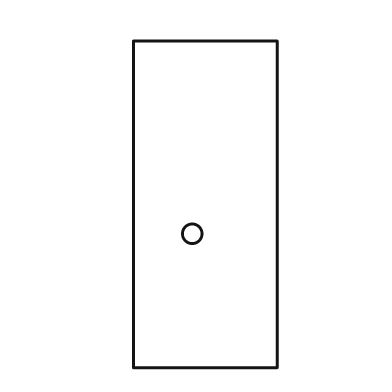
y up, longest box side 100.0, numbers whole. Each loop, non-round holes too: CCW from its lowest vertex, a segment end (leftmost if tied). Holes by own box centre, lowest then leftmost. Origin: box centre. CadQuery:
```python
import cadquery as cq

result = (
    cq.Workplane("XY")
    .moveTo(-22.0, -50.0)
    .lineTo(22.0, -50.0)
    .lineTo(22.0, 50.0)
    .lineTo(-22.0, 50.0)
    .close()
    .moveTo(-4.0, -9.0)
    .circle(3.0)
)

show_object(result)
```